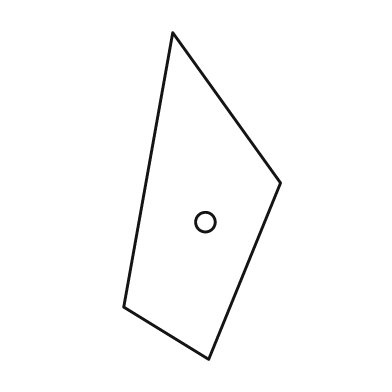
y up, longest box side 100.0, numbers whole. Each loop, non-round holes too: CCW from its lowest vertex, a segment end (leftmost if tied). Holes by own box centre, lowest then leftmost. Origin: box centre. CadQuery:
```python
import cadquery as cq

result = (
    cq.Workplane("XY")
    .moveTo(2.0, -50.0)
    .lineTo(24.0, 4.0)
    .lineTo(-9.0, 50.0)
    .lineTo(-24.0, -34.0)
    .close()
    .moveTo(1.0, -8.0)
    .circle(3.0)
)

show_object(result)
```